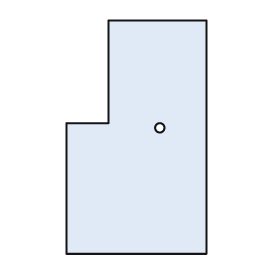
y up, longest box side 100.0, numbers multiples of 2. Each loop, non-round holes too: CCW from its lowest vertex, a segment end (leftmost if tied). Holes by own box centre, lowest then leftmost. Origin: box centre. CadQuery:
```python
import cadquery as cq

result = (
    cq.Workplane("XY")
    .moveTo(-30.0, -50.0)
    .lineTo(30.0, -50.0)
    .lineTo(30.0, 50.0)
    .lineTo(-12.0, 50.0)
    .lineTo(-12.0, 6.0)
    .lineTo(-30.0, 6.0)
    .close()
    .moveTo(10.0, 4.0)
    .circle(2.0)
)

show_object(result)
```